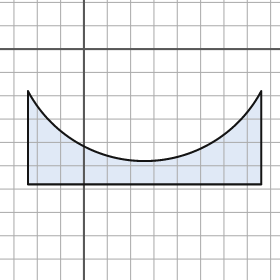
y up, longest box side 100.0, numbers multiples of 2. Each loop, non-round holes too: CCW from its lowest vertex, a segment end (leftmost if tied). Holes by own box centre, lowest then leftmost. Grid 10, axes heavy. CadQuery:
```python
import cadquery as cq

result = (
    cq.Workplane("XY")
    .moveTo(-24.0, -58.0)
    .lineTo(76.0, -58.0)
    .lineTo(76.0, -18.0)
    .threePointArc((26.0, -48.0), (-24.0, -18.0))
    .close()
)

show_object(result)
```